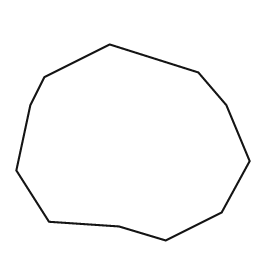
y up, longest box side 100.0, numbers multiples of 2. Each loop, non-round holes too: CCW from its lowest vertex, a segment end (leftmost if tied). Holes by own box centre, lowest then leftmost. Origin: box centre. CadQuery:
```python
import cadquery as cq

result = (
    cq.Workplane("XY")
    .moveTo(14.0, -42.0)
    .lineTo(38.0, -30.0)
    .lineTo(50.0, -8.0)
    .lineTo(40.0, 16.0)
    .lineTo(28.0, 30.0)
    .lineTo(-10.0, 42.0)
    .lineTo(-38.0, 28.0)
    .lineTo(-44.0, 16.0)
    .lineTo(-50.0, -12.0)
    .lineTo(-36.0, -34.0)
    .lineTo(-6.0, -36.0)
    .close()
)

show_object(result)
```